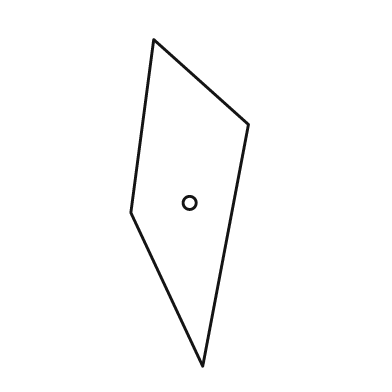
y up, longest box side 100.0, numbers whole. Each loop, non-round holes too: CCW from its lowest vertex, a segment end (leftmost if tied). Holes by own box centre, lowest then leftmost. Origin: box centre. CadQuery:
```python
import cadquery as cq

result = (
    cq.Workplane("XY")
    .moveTo(4.0, -50.0)
    .lineTo(18.0, 24.0)
    .lineTo(-11.0, 50.0)
    .lineTo(-18.0, -3.0)
    .close()
    .moveTo(0.0, 0.0)
    .circle(2.0)
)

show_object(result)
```